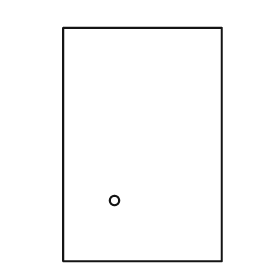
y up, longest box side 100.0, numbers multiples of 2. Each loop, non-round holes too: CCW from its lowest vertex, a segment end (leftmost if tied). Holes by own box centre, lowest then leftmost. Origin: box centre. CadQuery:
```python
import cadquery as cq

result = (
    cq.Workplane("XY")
    .moveTo(-34.0, -50.0)
    .lineTo(34.0, -50.0)
    .lineTo(34.0, 50.0)
    .lineTo(-34.0, 50.0)
    .close()
    .moveTo(-12.0, -24.0)
    .circle(2.0)
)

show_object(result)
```